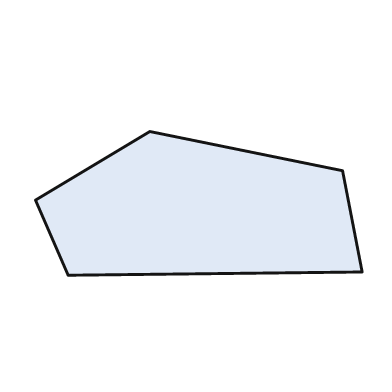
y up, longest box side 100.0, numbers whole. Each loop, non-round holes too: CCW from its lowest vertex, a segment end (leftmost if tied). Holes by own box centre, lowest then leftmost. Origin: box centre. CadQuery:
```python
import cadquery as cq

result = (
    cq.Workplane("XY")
    .moveTo(-40.0, -22.0)
    .lineTo(50.0, -21.0)
    .lineTo(44.0, 10.0)
    .lineTo(-15.0, 22.0)
    .lineTo(-50.0, 1.0)
    .close()
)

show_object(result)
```